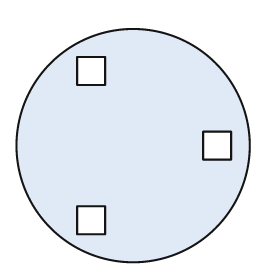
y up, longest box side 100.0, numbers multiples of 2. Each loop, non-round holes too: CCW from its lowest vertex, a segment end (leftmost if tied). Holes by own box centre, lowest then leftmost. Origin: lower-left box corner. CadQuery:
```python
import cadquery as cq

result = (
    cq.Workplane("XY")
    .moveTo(50.0, 50.0)
    .circle(50.0)
    .moveTo(26.0, 12.0)
    .lineTo(38.0, 12.0)
    .lineTo(38.0, 24.0)
    .lineTo(26.0, 24.0)
    .close()
    .moveTo(80.0, 44.0)
    .lineTo(92.0, 44.0)
    .lineTo(92.0, 56.0)
    .lineTo(80.0, 56.0)
    .close()
    .moveTo(26.0, 76.0)
    .lineTo(38.0, 76.0)
    .lineTo(38.0, 88.0)
    .lineTo(26.0, 88.0)
    .close()
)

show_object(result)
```